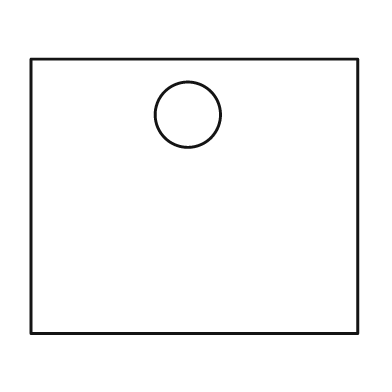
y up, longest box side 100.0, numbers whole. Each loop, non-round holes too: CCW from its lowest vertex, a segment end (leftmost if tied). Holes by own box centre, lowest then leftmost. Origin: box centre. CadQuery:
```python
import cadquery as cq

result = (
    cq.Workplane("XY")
    .moveTo(-50.0, -42.0)
    .lineTo(50.0, -42.0)
    .lineTo(50.0, 42.0)
    .lineTo(-50.0, 42.0)
    .close()
    .moveTo(-2.0, 25.0)
    .circle(10.0)
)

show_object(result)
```